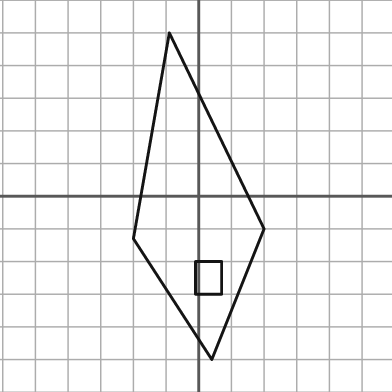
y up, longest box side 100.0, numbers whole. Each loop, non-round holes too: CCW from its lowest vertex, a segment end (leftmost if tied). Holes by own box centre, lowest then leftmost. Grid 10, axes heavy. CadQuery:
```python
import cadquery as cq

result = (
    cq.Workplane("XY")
    .moveTo(4.0, -50.0)
    .lineTo(20.0, -10.0)
    .lineTo(-9.0, 50.0)
    .lineTo(-20.0, -13.0)
    .close()
    .moveTo(-1.0, -30.0)
    .lineTo(7.0, -30.0)
    .lineTo(7.0, -20.0)
    .lineTo(-1.0, -20.0)
    .close()
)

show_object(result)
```